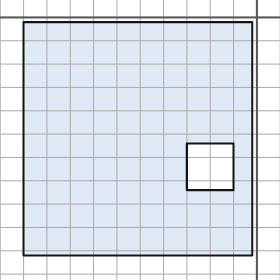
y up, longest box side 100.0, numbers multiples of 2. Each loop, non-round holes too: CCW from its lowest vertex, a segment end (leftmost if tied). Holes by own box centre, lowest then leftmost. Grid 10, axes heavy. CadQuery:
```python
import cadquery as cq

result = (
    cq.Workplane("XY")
    .moveTo(-100.0, -102.0)
    .lineTo(-2.0, -102.0)
    .lineTo(-2.0, -2.0)
    .lineTo(-100.0, -2.0)
    .close()
    .moveTo(-30.0, -74.0)
    .lineTo(-10.0, -74.0)
    .lineTo(-10.0, -54.0)
    .lineTo(-30.0, -54.0)
    .close()
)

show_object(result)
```